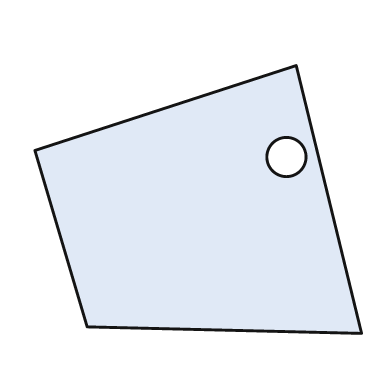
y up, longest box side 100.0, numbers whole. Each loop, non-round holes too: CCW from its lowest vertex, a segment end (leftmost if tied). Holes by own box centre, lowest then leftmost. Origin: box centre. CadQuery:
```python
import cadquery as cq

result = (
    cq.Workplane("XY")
    .moveTo(50.0, -41.0)
    .lineTo(30.0, 41.0)
    .lineTo(-50.0, 15.0)
    .lineTo(-34.0, -39.0)
    .close()
    .moveTo(27.0, 13.0)
    .circle(6.0)
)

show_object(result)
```